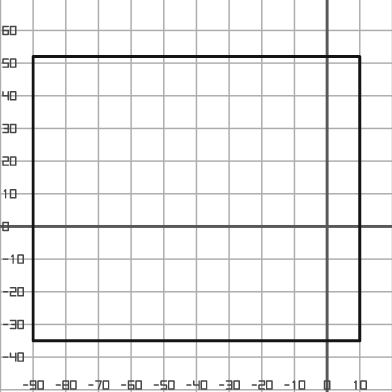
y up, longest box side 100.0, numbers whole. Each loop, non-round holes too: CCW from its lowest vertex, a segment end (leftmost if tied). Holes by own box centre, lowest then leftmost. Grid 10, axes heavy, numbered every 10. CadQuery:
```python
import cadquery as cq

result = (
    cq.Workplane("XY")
    .moveTo(-90.0, -35.0)
    .lineTo(10.0, -35.0)
    .lineTo(10.0, 52.0)
    .lineTo(-90.0, 52.0)
    .close()
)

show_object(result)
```